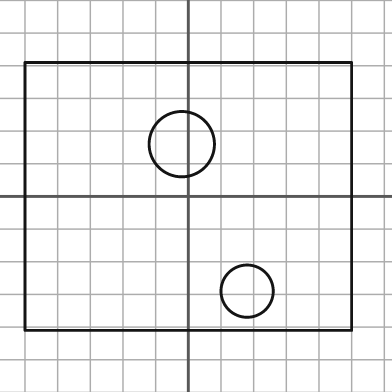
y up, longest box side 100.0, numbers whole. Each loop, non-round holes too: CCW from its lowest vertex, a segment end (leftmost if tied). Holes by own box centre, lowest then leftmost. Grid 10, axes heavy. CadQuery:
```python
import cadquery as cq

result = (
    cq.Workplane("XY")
    .moveTo(-50.0, -41.0)
    .lineTo(50.0, -41.0)
    .lineTo(50.0, 41.0)
    .lineTo(-50.0, 41.0)
    .close()
    .moveTo(18.0, -29.0)
    .circle(8.0)
    .moveTo(-2.0, 16.0)
    .circle(10.0)
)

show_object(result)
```